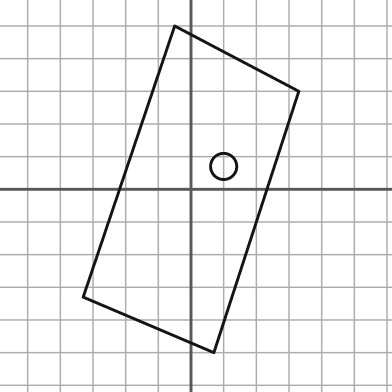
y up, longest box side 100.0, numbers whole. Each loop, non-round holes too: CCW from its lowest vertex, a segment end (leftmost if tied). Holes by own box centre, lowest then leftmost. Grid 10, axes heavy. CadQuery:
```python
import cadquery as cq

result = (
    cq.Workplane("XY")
    .moveTo(7.0, -50.0)
    .lineTo(33.0, 30.0)
    .lineTo(-5.0, 50.0)
    .lineTo(-33.0, -33.0)
    .close()
    .moveTo(10.0, 7.0)
    .circle(4.0)
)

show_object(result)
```